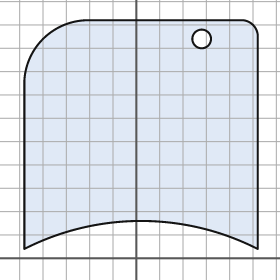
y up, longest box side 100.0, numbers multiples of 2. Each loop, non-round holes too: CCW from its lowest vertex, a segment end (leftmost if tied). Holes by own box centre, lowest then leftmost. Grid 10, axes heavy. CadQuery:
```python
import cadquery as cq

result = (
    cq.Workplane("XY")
    .moveTo(-48.0, 4.0)
    .threePointArc((2.0, 16.0), (52.0, 4.0))
    .lineTo(52.0, 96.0)
    .threePointArc((50.0, 100.0), (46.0, 102.0))
    .lineTo(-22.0, 102.0)
    .threePointArc((-40.0, 94.0), (-48.0, 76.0))
    .close()
    .moveTo(28.0, 94.0)
    .circle(4.0)
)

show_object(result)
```